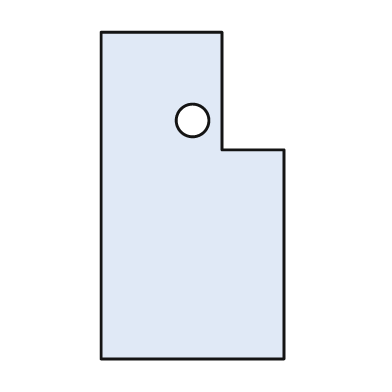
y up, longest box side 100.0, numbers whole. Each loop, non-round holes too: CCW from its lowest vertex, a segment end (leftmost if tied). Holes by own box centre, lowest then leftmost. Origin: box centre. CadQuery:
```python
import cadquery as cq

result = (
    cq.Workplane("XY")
    .moveTo(-28.0, -50.0)
    .lineTo(28.0, -50.0)
    .lineTo(28.0, 14.0)
    .lineTo(9.0, 14.0)
    .lineTo(9.0, 50.0)
    .lineTo(-28.0, 50.0)
    .close()
    .moveTo(0.0, 23.0)
    .circle(5.0)
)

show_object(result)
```